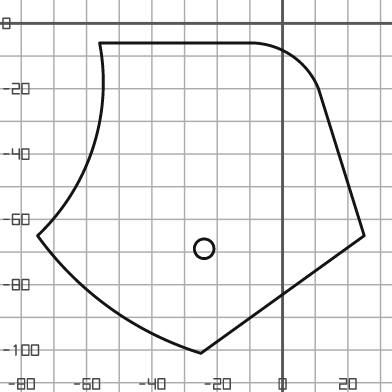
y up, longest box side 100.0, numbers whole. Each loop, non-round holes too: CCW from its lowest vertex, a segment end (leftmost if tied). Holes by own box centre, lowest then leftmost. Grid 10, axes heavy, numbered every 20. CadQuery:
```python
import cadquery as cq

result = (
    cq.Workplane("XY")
    .moveTo(-25.0, -101.0)
    .lineTo(25.0, -65.0)
    .lineTo(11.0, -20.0)
    .threePointArc((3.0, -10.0), (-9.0, -6.0))
    .lineTo(-56.0, -6.0)
    .threePointArc((-58.0, -38.0), (-75.0, -65.0))
    .threePointArc((-53.0, -87.0), (-25.0, -101.0))
    .close()
    .moveTo(-24.0, -69.0)
    .circle(3.0)
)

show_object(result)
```